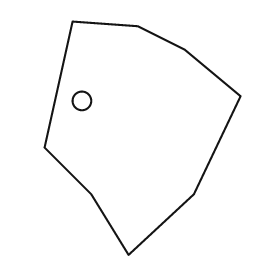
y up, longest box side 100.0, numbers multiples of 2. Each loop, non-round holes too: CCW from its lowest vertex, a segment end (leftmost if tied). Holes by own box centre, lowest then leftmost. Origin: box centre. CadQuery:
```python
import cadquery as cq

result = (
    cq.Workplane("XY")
    .moveTo(-6.0, -50.0)
    .lineTo(22.0, -24.0)
    .lineTo(42.0, 18.0)
    .lineTo(18.0, 38.0)
    .lineTo(-2.0, 48.0)
    .lineTo(-30.0, 50.0)
    .lineTo(-42.0, -4.0)
    .lineTo(-22.0, -24.0)
    .close()
    .moveTo(-26.0, 16.0)
    .circle(4.0)
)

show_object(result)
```